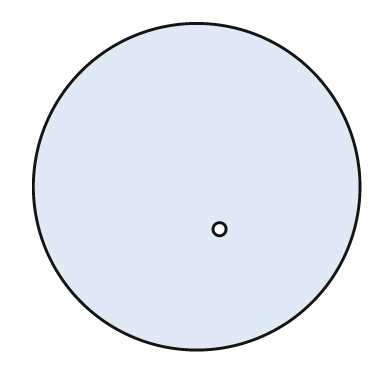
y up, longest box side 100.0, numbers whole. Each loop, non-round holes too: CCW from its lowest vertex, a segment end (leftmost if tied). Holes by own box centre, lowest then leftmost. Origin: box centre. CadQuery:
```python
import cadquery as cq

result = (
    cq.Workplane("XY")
    .moveTo(0.0, 0.0)
    .circle(50.0)
    .moveTo(7.0, -13.0)
    .circle(2.0)
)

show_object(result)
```